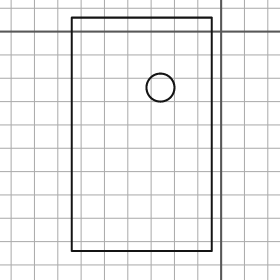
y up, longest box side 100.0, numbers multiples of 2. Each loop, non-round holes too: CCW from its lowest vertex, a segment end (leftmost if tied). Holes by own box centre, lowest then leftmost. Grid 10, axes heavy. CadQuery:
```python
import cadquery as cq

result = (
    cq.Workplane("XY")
    .moveTo(-64.0, -94.0)
    .lineTo(-4.0, -94.0)
    .lineTo(-4.0, 6.0)
    .lineTo(-64.0, 6.0)
    .close()
    .moveTo(-26.0, -24.0)
    .circle(6.0)
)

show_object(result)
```